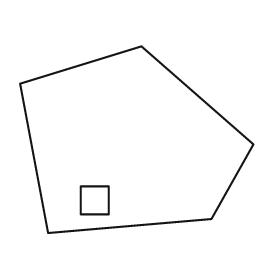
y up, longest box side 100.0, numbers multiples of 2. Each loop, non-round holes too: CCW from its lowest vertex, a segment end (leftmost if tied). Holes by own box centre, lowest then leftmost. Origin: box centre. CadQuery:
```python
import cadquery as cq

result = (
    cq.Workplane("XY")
    .moveTo(-38.0, -40.0)
    .lineTo(32.0, -34.0)
    .lineTo(50.0, -2.0)
    .lineTo(2.0, 40.0)
    .lineTo(-50.0, 24.0)
    .close()
    .moveTo(-24.0, -32.0)
    .lineTo(-12.0, -32.0)
    .lineTo(-12.0, -20.0)
    .lineTo(-24.0, -20.0)
    .close()
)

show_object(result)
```